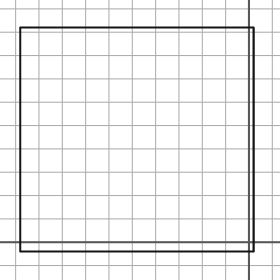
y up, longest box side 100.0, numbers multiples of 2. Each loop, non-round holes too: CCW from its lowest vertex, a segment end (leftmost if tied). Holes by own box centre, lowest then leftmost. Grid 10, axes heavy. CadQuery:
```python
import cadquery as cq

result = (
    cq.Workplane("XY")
    .moveTo(-98.0, -4.0)
    .lineTo(2.0, -4.0)
    .lineTo(2.0, 92.0)
    .lineTo(-98.0, 92.0)
    .close()
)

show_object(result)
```